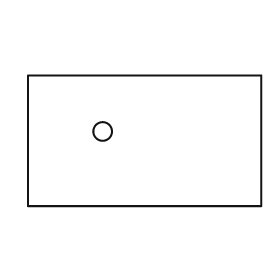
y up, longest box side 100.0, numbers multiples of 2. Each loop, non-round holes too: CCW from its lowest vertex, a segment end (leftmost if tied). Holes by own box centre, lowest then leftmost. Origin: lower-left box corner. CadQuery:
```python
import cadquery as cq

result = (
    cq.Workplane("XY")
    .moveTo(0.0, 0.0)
    .lineTo(100.0, 0.0)
    .lineTo(100.0, 56.0)
    .lineTo(0.0, 56.0)
    .close()
    .moveTo(32.0, 32.0)
    .circle(4.0)
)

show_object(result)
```